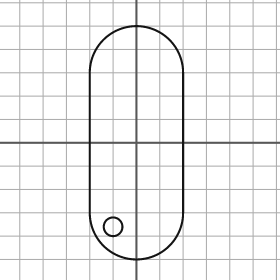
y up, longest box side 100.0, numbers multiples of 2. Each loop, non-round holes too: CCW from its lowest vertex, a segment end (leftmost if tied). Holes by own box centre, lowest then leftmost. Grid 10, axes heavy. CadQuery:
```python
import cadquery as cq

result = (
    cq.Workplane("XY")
    .moveTo(-20.0, -30.0)
    .threePointArc((0.0, -50.0), (20.0, -30.0))
    .lineTo(20.0, 30.0)
    .threePointArc((0.0, 50.0), (-20.0, 30.0))
    .close()
    .moveTo(-10.0, -36.0)
    .circle(4.0)
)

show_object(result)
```